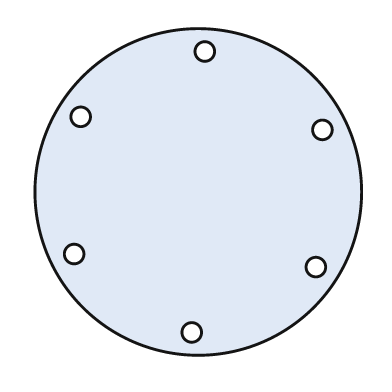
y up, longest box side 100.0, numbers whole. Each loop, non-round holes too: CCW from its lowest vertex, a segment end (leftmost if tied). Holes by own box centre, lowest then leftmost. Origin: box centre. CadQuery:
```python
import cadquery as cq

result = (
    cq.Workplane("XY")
    .moveTo(0.0, 0.0)
    .circle(50.0)
    .moveTo(-2.0, -43.0)
    .circle(3.0)
    .moveTo(36.0, -23.0)
    .circle(3.0)
    .moveTo(-38.0, -19.0)
    .circle(3.0)
    .moveTo(38.0, 19.0)
    .circle(3.0)
    .moveTo(-36.0, 23.0)
    .circle(3.0)
    .moveTo(2.0, 43.0)
    .circle(3.0)
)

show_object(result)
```